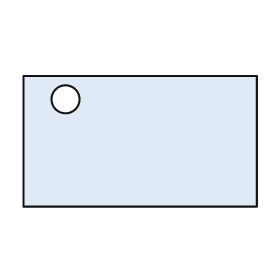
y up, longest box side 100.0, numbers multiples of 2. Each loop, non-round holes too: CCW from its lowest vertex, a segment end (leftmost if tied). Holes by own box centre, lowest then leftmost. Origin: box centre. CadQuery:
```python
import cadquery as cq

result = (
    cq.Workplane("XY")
    .moveTo(-50.0, -28.0)
    .lineTo(50.0, -28.0)
    .lineTo(50.0, 28.0)
    .lineTo(-50.0, 28.0)
    .close()
    .moveTo(-32.0, 18.0)
    .circle(6.0)
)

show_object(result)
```